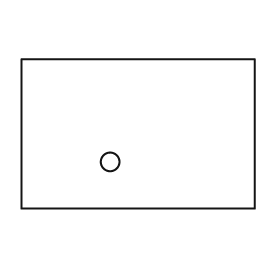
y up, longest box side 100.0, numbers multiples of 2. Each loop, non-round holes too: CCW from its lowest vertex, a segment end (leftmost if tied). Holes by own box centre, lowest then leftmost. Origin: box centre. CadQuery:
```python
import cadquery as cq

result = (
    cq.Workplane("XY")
    .moveTo(-50.0, -32.0)
    .lineTo(50.0, -32.0)
    .lineTo(50.0, 32.0)
    .lineTo(-50.0, 32.0)
    .close()
    .moveTo(-12.0, -12.0)
    .circle(4.0)
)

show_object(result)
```